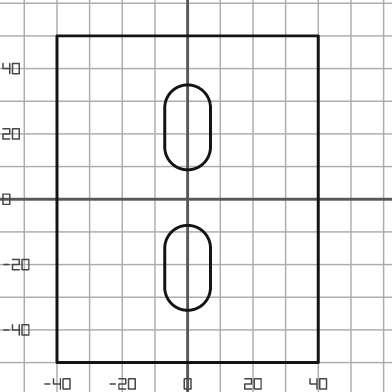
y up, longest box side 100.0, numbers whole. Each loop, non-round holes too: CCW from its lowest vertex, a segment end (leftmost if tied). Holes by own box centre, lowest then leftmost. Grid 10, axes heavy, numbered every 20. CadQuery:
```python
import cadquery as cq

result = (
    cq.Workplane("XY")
    .moveTo(-40.0, -50.0)
    .lineTo(40.0, -50.0)
    .lineTo(40.0, 50.0)
    .lineTo(-40.0, 50.0)
    .close()
    .moveTo(-7.0, -27.0)
    .threePointArc((0.0, -34.0), (7.0, -27.0))
    .lineTo(7.0, -15.0)
    .threePointArc((0.0, -8.0), (-7.0, -15.0))
    .close()
    .moveTo(-7.0, 16.0)
    .threePointArc((0.0, 9.0), (7.0, 16.0))
    .lineTo(7.0, 28.0)
    .threePointArc((0.0, 35.0), (-7.0, 28.0))
    .close()
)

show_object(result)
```